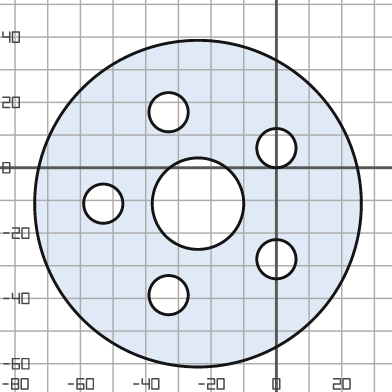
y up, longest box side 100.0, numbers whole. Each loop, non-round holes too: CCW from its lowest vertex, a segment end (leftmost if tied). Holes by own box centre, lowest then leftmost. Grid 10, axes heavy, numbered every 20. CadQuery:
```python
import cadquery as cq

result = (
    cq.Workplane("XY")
    .moveTo(-24.0, -11.0)
    .circle(50.0)
    .moveTo(-33.0, -39.0)
    .circle(6.0)
    .moveTo(0.0, -28.0)
    .circle(6.0)
    .moveTo(-53.0, -11.0)
    .circle(6.0)
    .moveTo(-24.0, -11.0)
    .circle(14.0)
    .moveTo(0.0, 6.0)
    .circle(6.0)
    .moveTo(-33.0, 17.0)
    .circle(6.0)
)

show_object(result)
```